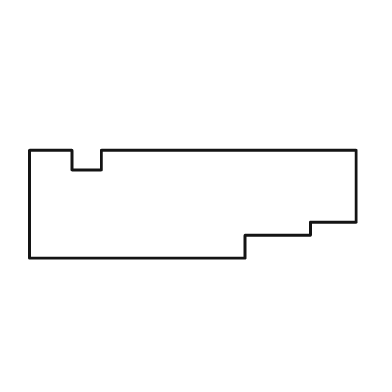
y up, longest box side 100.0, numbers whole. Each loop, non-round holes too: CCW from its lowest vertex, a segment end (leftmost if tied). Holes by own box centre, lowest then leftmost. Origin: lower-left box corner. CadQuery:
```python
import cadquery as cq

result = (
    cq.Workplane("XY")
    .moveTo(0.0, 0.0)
    .lineTo(66.0, 0.0)
    .lineTo(66.0, 7.0)
    .lineTo(86.0, 7.0)
    .lineTo(86.0, 11.0)
    .lineTo(100.0, 11.0)
    .lineTo(100.0, 33.0)
    .lineTo(22.0, 33.0)
    .lineTo(22.0, 27.0)
    .lineTo(13.0, 27.0)
    .lineTo(13.0, 33.0)
    .lineTo(0.0, 33.0)
    .close()
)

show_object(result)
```